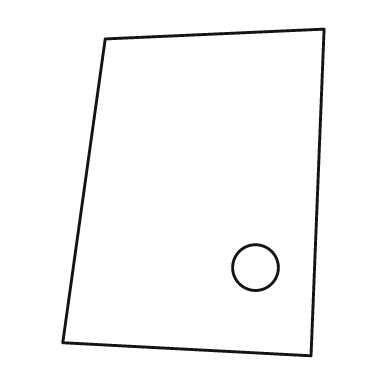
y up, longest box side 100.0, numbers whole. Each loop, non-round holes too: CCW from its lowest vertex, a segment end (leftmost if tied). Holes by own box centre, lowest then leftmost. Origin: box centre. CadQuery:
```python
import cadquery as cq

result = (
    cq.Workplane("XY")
    .moveTo(36.0, -50.0)
    .lineTo(40.0, 50.0)
    .lineTo(-27.0, 47.0)
    .lineTo(-40.0, -46.0)
    .close()
    .moveTo(19.0, -23.0)
    .circle(7.0)
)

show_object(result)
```